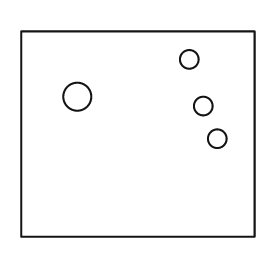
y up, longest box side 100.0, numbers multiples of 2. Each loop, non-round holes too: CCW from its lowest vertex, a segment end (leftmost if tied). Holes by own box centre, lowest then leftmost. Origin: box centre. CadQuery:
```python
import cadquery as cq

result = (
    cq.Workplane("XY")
    .moveTo(-50.0, -44.0)
    .lineTo(50.0, -44.0)
    .lineTo(50.0, 44.0)
    .lineTo(-50.0, 44.0)
    .close()
    .moveTo(34.0, -2.0)
    .circle(4.0)
    .moveTo(28.0, 12.0)
    .circle(4.0)
    .moveTo(-26.0, 16.0)
    .circle(6.0)
    .moveTo(22.0, 32.0)
    .circle(4.0)
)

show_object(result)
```